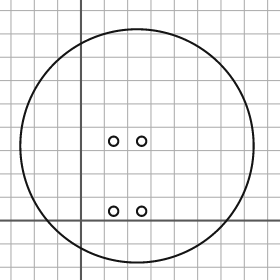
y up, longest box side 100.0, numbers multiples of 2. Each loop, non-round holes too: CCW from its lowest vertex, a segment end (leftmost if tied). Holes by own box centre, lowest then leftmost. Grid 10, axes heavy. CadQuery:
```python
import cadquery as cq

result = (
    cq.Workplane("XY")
    .moveTo(24.0, 32.0)
    .circle(50.0)
    .moveTo(14.0, 4.0)
    .circle(2.0)
    .moveTo(26.0, 4.0)
    .circle(2.0)
    .moveTo(14.0, 34.0)
    .circle(2.0)
    .moveTo(26.0, 34.0)
    .circle(2.0)
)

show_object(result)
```